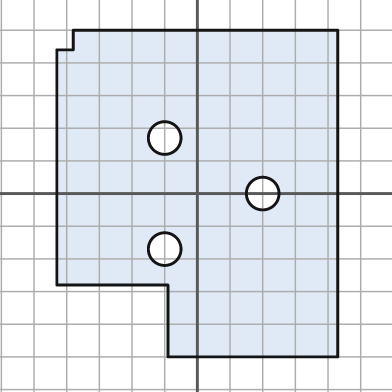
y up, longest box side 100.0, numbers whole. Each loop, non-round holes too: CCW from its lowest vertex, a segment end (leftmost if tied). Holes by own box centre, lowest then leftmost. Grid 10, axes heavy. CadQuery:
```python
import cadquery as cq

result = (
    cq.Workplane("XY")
    .moveTo(-9.0, -50.0)
    .lineTo(43.0, -50.0)
    .lineTo(43.0, 50.0)
    .lineTo(-38.0, 50.0)
    .lineTo(-38.0, 44.0)
    .lineTo(-43.0, 44.0)
    .lineTo(-43.0, -28.0)
    .lineTo(-9.0, -28.0)
    .close()
    .moveTo(-10.0, -17.0)
    .circle(5.0)
    .moveTo(20.0, 0.0)
    .circle(5.0)
    .moveTo(-10.0, 17.0)
    .circle(5.0)
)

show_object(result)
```